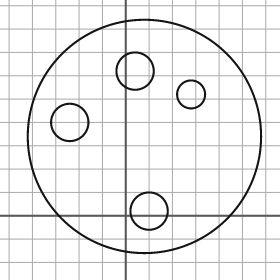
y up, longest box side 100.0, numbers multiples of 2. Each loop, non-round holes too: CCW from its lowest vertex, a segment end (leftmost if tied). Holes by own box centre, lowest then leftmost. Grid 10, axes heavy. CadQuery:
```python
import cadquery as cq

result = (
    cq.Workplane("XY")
    .moveTo(8.0, 34.0)
    .circle(50.0)
    .moveTo(10.0, 2.0)
    .circle(8.0)
    .moveTo(-24.0, 40.0)
    .circle(8.0)
    .moveTo(28.0, 52.0)
    .circle(6.0)
    .moveTo(4.0, 62.0)
    .circle(8.0)
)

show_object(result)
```